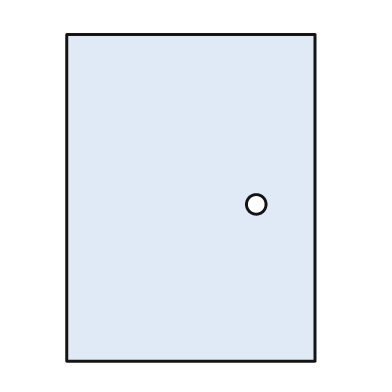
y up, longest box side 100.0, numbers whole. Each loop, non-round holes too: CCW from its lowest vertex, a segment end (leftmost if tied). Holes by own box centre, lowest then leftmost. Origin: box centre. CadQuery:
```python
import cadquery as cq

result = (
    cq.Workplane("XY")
    .moveTo(-38.0, -50.0)
    .lineTo(38.0, -50.0)
    .lineTo(38.0, 50.0)
    .lineTo(-38.0, 50.0)
    .close()
    .moveTo(20.0, -2.0)
    .circle(3.0)
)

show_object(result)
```